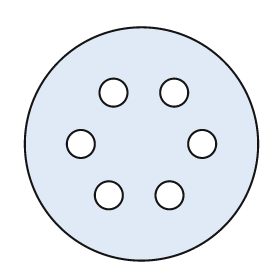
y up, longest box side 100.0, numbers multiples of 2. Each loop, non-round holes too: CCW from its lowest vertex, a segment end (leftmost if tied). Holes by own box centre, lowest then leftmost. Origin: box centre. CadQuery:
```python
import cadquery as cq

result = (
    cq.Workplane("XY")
    .moveTo(0.0, 0.0)
    .circle(50.0)
    .moveTo(-14.0, -22.0)
    .circle(6.0)
    .moveTo(12.0, -22.0)
    .circle(6.0)
    .moveTo(-26.0, 0.0)
    .circle(6.0)
    .moveTo(26.0, 0.0)
    .circle(6.0)
    .moveTo(-12.0, 22.0)
    .circle(6.0)
    .moveTo(14.0, 22.0)
    .circle(6.0)
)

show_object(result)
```